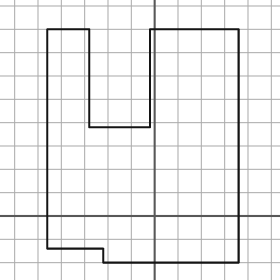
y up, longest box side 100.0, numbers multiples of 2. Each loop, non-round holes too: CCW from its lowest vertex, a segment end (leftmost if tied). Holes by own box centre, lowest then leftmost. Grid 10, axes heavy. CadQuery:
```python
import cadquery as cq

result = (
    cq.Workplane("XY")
    .moveTo(-22.0, -20.0)
    .lineTo(36.0, -20.0)
    .lineTo(36.0, 80.0)
    .lineTo(-2.0, 80.0)
    .lineTo(-2.0, 38.0)
    .lineTo(-28.0, 38.0)
    .lineTo(-28.0, 80.0)
    .lineTo(-46.0, 80.0)
    .lineTo(-46.0, -14.0)
    .lineTo(-22.0, -14.0)
    .close()
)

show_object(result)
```